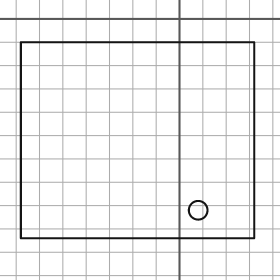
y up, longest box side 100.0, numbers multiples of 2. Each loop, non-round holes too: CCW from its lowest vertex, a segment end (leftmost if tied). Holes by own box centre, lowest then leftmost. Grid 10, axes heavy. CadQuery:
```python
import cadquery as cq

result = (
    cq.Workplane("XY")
    .moveTo(-68.0, -94.0)
    .lineTo(32.0, -94.0)
    .lineTo(32.0, -10.0)
    .lineTo(-68.0, -10.0)
    .close()
    .moveTo(8.0, -82.0)
    .circle(4.0)
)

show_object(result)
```